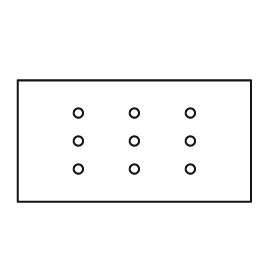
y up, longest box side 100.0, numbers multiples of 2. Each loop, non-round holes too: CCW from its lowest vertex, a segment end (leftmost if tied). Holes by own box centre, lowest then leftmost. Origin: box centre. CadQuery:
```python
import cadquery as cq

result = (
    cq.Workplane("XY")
    .moveTo(-50.0, -26.0)
    .lineTo(50.0, -26.0)
    .lineTo(50.0, 26.0)
    .lineTo(-50.0, 26.0)
    .close()
    .moveTo(-24.0, -12.0)
    .circle(2.0)
    .moveTo(0.0, -12.0)
    .circle(2.0)
    .moveTo(24.0, -12.0)
    .circle(2.0)
    .moveTo(-24.0, 0.0)
    .circle(2.0)
    .moveTo(0.0, 0.0)
    .circle(2.0)
    .moveTo(24.0, 0.0)
    .circle(2.0)
    .moveTo(-24.0, 12.0)
    .circle(2.0)
    .moveTo(0.0, 12.0)
    .circle(2.0)
    .moveTo(24.0, 12.0)
    .circle(2.0)
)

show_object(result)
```